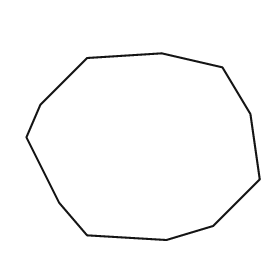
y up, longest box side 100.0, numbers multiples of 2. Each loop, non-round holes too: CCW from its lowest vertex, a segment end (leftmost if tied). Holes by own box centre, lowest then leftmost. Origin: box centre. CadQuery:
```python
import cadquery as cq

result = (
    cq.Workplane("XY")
    .moveTo(10.0, -40.0)
    .lineTo(30.0, -34.0)
    .lineTo(50.0, -14.0)
    .lineTo(46.0, 14.0)
    .lineTo(34.0, 34.0)
    .lineTo(8.0, 40.0)
    .lineTo(-24.0, 38.0)
    .lineTo(-44.0, 18.0)
    .lineTo(-50.0, 4.0)
    .lineTo(-36.0, -24.0)
    .lineTo(-24.0, -38.0)
    .close()
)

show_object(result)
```